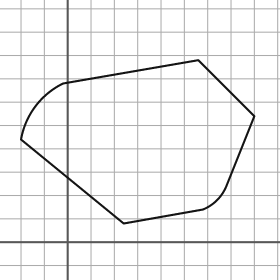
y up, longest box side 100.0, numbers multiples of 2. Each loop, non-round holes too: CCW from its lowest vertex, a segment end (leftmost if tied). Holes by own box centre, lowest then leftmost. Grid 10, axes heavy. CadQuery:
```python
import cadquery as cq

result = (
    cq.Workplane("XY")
    .moveTo(24.0, 8.0)
    .lineTo(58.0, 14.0)
    .threePointArc((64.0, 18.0), (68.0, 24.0))
    .lineTo(80.0, 54.0)
    .lineTo(56.0, 78.0)
    .lineTo(-2.0, 68.0)
    .threePointArc((-14.0, 58.0), (-20.0, 44.0))
    .close()
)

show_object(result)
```